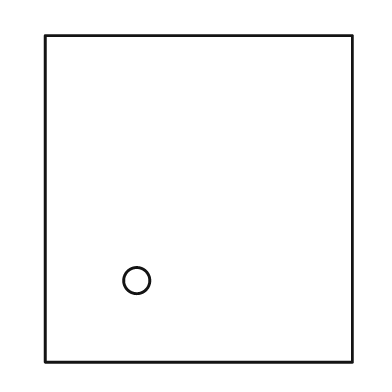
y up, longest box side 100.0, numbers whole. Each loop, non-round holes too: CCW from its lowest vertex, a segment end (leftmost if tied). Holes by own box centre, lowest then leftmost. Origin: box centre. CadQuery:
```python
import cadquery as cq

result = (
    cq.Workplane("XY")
    .moveTo(-47.0, -50.0)
    .lineTo(47.0, -50.0)
    .lineTo(47.0, 50.0)
    .lineTo(-47.0, 50.0)
    .close()
    .moveTo(-19.0, -25.0)
    .circle(4.0)
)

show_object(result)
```